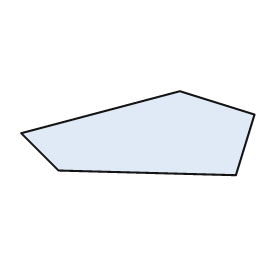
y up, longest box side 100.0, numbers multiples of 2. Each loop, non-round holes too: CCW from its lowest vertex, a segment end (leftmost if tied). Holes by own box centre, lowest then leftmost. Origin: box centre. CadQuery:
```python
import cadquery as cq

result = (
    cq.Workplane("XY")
    .moveTo(42.0, -18.0)
    .lineTo(50.0, 8.0)
    .lineTo(18.0, 18.0)
    .lineTo(-50.0, 0.0)
    .lineTo(-34.0, -16.0)
    .close()
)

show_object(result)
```